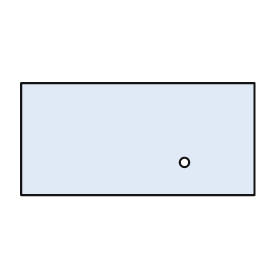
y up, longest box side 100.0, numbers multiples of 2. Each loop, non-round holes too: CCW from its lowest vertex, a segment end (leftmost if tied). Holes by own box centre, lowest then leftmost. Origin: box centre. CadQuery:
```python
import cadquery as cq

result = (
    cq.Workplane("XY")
    .moveTo(-50.0, -24.0)
    .lineTo(50.0, -24.0)
    .lineTo(50.0, 24.0)
    .lineTo(-50.0, 24.0)
    .close()
    .moveTo(20.0, -10.0)
    .circle(2.0)
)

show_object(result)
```